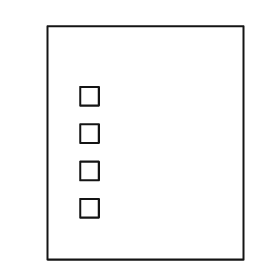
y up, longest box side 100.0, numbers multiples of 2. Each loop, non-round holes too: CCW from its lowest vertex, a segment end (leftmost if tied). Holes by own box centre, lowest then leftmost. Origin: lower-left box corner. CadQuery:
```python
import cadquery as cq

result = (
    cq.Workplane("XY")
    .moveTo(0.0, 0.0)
    .lineTo(84.0, 0.0)
    .lineTo(84.0, 100.0)
    .lineTo(0.0, 100.0)
    .close()
    .moveTo(14.0, 18.0)
    .lineTo(22.0, 18.0)
    .lineTo(22.0, 26.0)
    .lineTo(14.0, 26.0)
    .close()
    .moveTo(14.0, 34.0)
    .lineTo(22.0, 34.0)
    .lineTo(22.0, 42.0)
    .lineTo(14.0, 42.0)
    .close()
    .moveTo(14.0, 50.0)
    .lineTo(22.0, 50.0)
    .lineTo(22.0, 58.0)
    .lineTo(14.0, 58.0)
    .close()
    .moveTo(14.0, 66.0)
    .lineTo(22.0, 66.0)
    .lineTo(22.0, 74.0)
    .lineTo(14.0, 74.0)
    .close()
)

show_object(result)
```